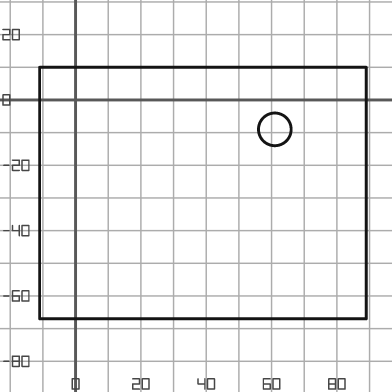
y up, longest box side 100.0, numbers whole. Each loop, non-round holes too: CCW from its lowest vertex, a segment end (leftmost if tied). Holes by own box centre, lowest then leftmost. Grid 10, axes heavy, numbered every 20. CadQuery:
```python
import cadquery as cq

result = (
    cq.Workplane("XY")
    .moveTo(-11.0, -67.0)
    .lineTo(89.0, -67.0)
    .lineTo(89.0, 10.0)
    .lineTo(-11.0, 10.0)
    .close()
    .moveTo(61.0, -9.0)
    .circle(5.0)
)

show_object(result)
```